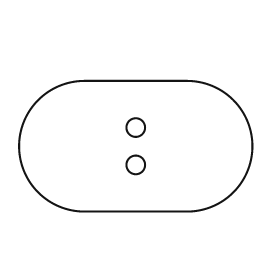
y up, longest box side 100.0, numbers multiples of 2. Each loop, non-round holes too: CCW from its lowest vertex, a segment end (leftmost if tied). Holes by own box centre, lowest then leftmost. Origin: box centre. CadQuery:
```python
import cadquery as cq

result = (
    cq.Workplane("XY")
    .moveTo(-22.0, -28.0)
    .lineTo(22.0, -28.0)
    .threePointArc((50.0, 0.0), (22.0, 28.0))
    .lineTo(-22.0, 28.0)
    .threePointArc((-50.0, 0.0), (-22.0, -28.0))
    .close()
    .moveTo(0.0, -8.0)
    .circle(4.0)
    .moveTo(0.0, 8.0)
    .circle(4.0)
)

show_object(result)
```